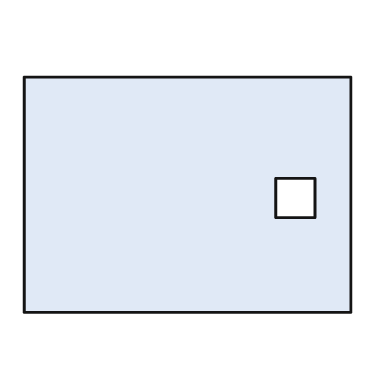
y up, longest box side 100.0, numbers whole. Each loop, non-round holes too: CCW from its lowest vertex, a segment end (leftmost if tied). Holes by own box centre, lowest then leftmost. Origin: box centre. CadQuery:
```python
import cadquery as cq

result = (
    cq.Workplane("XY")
    .moveTo(-50.0, -36.0)
    .lineTo(50.0, -36.0)
    .lineTo(50.0, 36.0)
    .lineTo(-50.0, 36.0)
    .close()
    .moveTo(27.0, -7.0)
    .lineTo(39.0, -7.0)
    .lineTo(39.0, 5.0)
    .lineTo(27.0, 5.0)
    .close()
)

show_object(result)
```